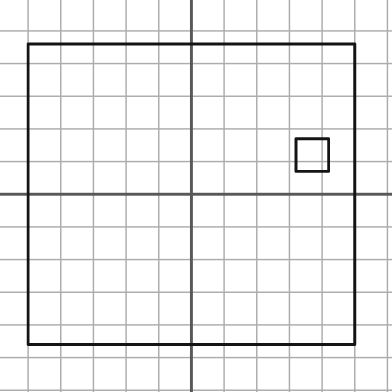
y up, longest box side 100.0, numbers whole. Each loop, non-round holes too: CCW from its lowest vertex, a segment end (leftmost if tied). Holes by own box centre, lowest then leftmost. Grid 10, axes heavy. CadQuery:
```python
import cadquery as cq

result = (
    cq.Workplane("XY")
    .moveTo(-50.0, -46.0)
    .lineTo(50.0, -46.0)
    .lineTo(50.0, 46.0)
    .lineTo(-50.0, 46.0)
    .close()
    .moveTo(32.0, 7.0)
    .lineTo(42.0, 7.0)
    .lineTo(42.0, 17.0)
    .lineTo(32.0, 17.0)
    .close()
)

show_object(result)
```